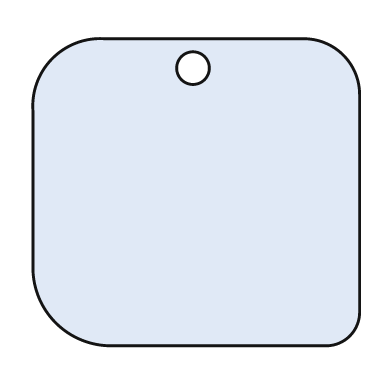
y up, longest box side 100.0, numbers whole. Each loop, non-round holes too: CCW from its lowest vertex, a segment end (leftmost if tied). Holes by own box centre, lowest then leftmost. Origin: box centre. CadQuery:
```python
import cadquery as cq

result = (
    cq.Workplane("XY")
    .moveTo(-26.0, -47.0)
    .lineTo(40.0, -47.0)
    .threePointArc((47.0, -44.0), (50.0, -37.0))
    .lineTo(50.0, 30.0)
    .threePointArc((45.0, 42.0), (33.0, 47.0))
    .lineTo(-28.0, 47.0)
    .threePointArc((-44.0, 41.0), (-50.0, 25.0))
    .lineTo(-50.0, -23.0)
    .threePointArc((-43.0, -40.0), (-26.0, -47.0))
    .close()
    .moveTo(-1.0, 38.0)
    .circle(5.0)
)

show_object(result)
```